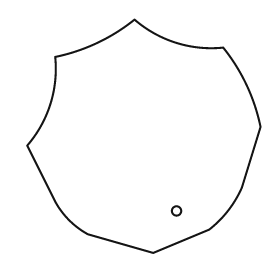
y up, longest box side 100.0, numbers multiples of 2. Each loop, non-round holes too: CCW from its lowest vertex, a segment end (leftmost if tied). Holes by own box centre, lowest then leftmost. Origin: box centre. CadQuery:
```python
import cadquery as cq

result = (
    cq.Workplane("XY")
    .moveTo(4.0, -50.0)
    .lineTo(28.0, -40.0)
    .threePointArc((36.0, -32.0), (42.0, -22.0))
    .lineTo(50.0, 4.0)
    .threePointArc((44.0, 22.0), (34.0, 38.0))
    .threePointArc((14.0, 40.0), (-4.0, 50.0))
    .threePointArc((-20.0, 40.0), (-38.0, 34.0))
    .threePointArc((-40.0, 14.0), (-50.0, -4.0))
    .lineTo(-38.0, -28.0)
    .threePointArc((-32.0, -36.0), (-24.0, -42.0))
    .close()
    .moveTo(14.0, -32.0)
    .circle(2.0)
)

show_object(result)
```